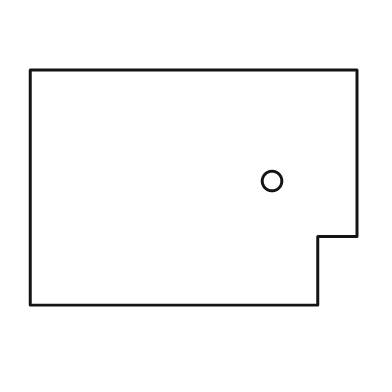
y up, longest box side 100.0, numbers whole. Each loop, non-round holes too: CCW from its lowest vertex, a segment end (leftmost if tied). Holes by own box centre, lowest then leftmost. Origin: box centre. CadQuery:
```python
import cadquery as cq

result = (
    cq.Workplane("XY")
    .moveTo(-50.0, -36.0)
    .lineTo(38.0, -36.0)
    .lineTo(38.0, -15.0)
    .lineTo(50.0, -15.0)
    .lineTo(50.0, 36.0)
    .lineTo(-50.0, 36.0)
    .close()
    .moveTo(24.0, 2.0)
    .circle(3.0)
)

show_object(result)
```